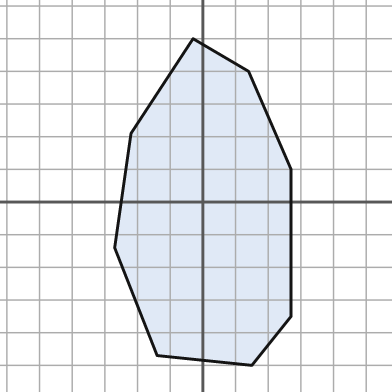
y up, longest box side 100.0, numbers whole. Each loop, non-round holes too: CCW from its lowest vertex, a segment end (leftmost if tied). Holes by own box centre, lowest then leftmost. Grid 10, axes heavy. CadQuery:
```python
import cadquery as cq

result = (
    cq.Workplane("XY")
    .moveTo(15.0, -50.0)
    .lineTo(27.0, -35.0)
    .lineTo(27.0, 10.0)
    .lineTo(14.0, 40.0)
    .lineTo(-3.0, 50.0)
    .lineTo(-22.0, 21.0)
    .lineTo(-27.0, -14.0)
    .lineTo(-14.0, -47.0)
    .close()
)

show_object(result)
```